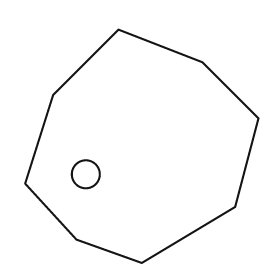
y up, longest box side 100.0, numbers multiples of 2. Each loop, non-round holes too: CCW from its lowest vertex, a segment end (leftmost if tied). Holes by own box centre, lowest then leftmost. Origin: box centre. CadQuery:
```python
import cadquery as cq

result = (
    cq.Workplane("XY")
    .moveTo(0.0, -50.0)
    .lineTo(40.0, -26.0)
    .lineTo(50.0, 12.0)
    .lineTo(26.0, 36.0)
    .lineTo(-10.0, 50.0)
    .lineTo(-38.0, 22.0)
    .lineTo(-50.0, -16.0)
    .lineTo(-28.0, -40.0)
    .close()
    .moveTo(-24.0, -12.0)
    .circle(6.0)
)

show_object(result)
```